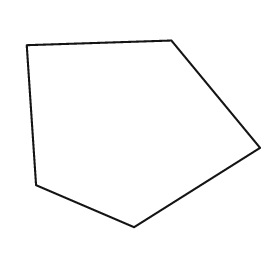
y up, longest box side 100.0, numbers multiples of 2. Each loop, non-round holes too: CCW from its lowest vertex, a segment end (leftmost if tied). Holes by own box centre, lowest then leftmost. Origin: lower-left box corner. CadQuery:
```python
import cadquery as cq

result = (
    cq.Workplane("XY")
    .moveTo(46.0, 0.0)
    .lineTo(100.0, 34.0)
    .lineTo(62.0, 80.0)
    .lineTo(0.0, 78.0)
    .lineTo(4.0, 18.0)
    .close()
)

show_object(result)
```